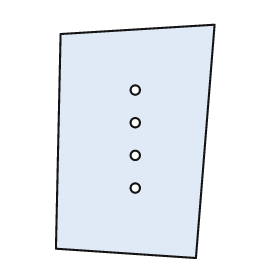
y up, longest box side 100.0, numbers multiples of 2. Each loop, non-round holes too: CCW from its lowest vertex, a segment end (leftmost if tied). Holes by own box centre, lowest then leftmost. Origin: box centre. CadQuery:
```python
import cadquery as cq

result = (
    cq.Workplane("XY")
    .moveTo(26.0, -50.0)
    .lineTo(34.0, 50.0)
    .lineTo(-32.0, 46.0)
    .lineTo(-34.0, -46.0)
    .close()
    .moveTo(0.0, -20.0)
    .circle(2.0)
    .moveTo(0.0, -6.0)
    .circle(2.0)
    .moveTo(0.0, 8.0)
    .circle(2.0)
    .moveTo(0.0, 22.0)
    .circle(2.0)
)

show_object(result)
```